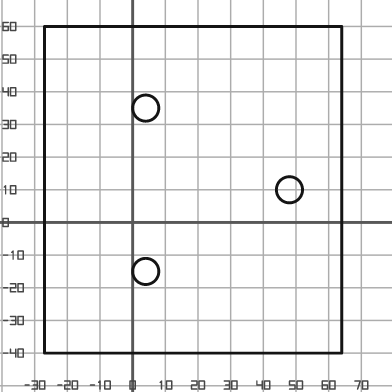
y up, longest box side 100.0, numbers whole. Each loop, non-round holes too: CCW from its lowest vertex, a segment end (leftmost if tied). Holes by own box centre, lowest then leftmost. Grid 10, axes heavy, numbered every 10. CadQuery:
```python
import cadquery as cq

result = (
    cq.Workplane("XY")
    .moveTo(-27.0, -40.0)
    .lineTo(64.0, -40.0)
    .lineTo(64.0, 60.0)
    .lineTo(-27.0, 60.0)
    .close()
    .moveTo(4.0, -15.0)
    .circle(4.0)
    .moveTo(48.0, 10.0)
    .circle(4.0)
    .moveTo(4.0, 35.0)
    .circle(4.0)
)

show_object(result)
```